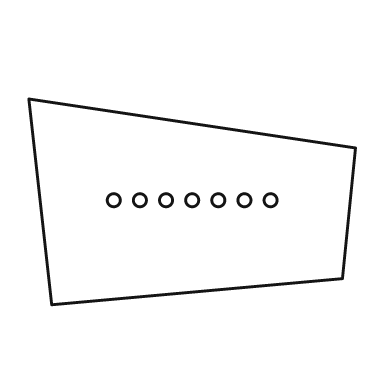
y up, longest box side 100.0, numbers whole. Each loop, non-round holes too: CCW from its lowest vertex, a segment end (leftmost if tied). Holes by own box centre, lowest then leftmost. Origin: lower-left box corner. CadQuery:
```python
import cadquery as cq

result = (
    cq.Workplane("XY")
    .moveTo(7.0, 0.0)
    .lineTo(96.0, 8.0)
    .lineTo(100.0, 48.0)
    .lineTo(0.0, 63.0)
    .close()
    .moveTo(26.0, 32.0)
    .circle(2.0)
    .moveTo(34.0, 32.0)
    .circle(2.0)
    .moveTo(42.0, 32.0)
    .circle(2.0)
    .moveTo(50.0, 32.0)
    .circle(2.0)
    .moveTo(58.0, 32.0)
    .circle(2.0)
    .moveTo(66.0, 32.0)
    .circle(2.0)
    .moveTo(74.0, 32.0)
    .circle(2.0)
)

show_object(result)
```